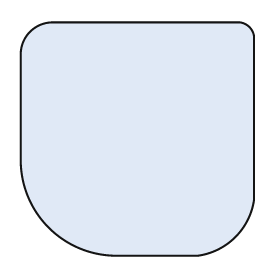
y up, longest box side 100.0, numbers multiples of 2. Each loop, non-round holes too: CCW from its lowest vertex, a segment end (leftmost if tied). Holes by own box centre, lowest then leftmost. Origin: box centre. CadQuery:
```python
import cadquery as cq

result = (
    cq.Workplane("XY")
    .moveTo(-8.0, -50.0)
    .lineTo(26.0, -50.0)
    .threePointArc((42.0, -42.0), (50.0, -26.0))
    .lineTo(50.0, 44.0)
    .threePointArc((48.0, 48.0), (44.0, 50.0))
    .lineTo(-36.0, 50.0)
    .threePointArc((-46.0, 46.0), (-50.0, 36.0))
    .lineTo(-50.0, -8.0)
    .threePointArc((-38.0, -38.0), (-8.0, -50.0))
    .close()
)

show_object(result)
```